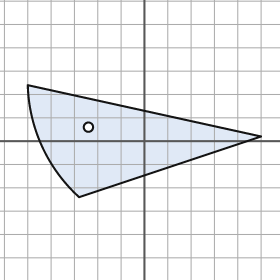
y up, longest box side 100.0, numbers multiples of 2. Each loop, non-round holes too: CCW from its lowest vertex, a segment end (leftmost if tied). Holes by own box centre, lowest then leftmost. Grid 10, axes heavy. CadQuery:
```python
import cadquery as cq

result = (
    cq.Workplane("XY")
    .moveTo(-28.0, -24.0)
    .lineTo(50.0, 2.0)
    .lineTo(-50.0, 24.0)
    .threePointArc((-44.0, -2.0), (-28.0, -24.0))
    .close()
    .moveTo(-24.0, 6.0)
    .circle(2.0)
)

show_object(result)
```